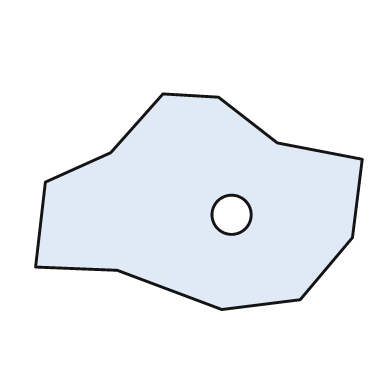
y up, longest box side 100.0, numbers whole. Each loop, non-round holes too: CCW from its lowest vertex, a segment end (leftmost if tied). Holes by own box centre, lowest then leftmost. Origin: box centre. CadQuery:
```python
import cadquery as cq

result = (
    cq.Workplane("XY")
    .moveTo(7.0, -33.0)
    .lineTo(31.0, -30.0)
    .lineTo(47.0, -11.0)
    .lineTo(50.0, 13.0)
    .lineTo(24.0, 18.0)
    .lineTo(6.0, 32.0)
    .lineTo(-11.0, 33.0)
    .lineTo(-27.0, 15.0)
    .lineTo(-47.0, 6.0)
    .lineTo(-50.0, -20.0)
    .lineTo(-25.0, -21.0)
    .close()
    .moveTo(10.0, -4.0)
    .circle(6.0)
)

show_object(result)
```